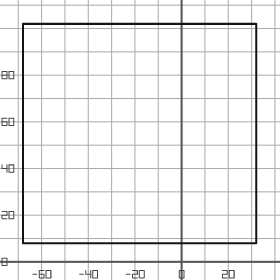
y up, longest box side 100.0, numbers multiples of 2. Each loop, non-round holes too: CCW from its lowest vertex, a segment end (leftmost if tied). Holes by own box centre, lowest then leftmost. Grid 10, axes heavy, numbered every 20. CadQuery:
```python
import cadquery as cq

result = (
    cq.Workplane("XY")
    .moveTo(-68.0, 8.0)
    .lineTo(32.0, 8.0)
    .lineTo(32.0, 102.0)
    .lineTo(-68.0, 102.0)
    .close()
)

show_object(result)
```